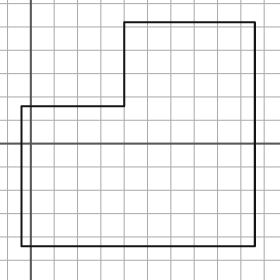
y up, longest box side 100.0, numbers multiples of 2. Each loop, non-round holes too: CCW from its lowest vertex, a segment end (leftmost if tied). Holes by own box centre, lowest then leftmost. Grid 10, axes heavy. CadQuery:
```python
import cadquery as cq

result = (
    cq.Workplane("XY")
    .moveTo(-4.0, -44.0)
    .lineTo(96.0, -44.0)
    .lineTo(96.0, 52.0)
    .lineTo(40.0, 52.0)
    .lineTo(40.0, 16.0)
    .lineTo(-4.0, 16.0)
    .close()
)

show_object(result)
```